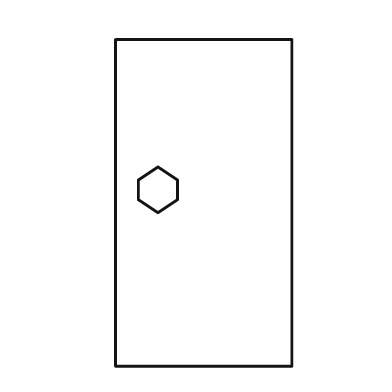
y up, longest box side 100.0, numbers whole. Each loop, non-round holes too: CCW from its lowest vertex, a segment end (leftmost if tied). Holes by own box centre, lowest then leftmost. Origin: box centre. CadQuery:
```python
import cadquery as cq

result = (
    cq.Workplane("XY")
    .moveTo(-27.0, -50.0)
    .lineTo(27.0, -50.0)
    .lineTo(27.0, 50.0)
    .lineTo(-27.0, 50.0)
    .close()
    .moveTo(-14.0, -3.0)
    .lineTo(-8.0, 1.0)
    .lineTo(-8.0, 7.0)
    .lineTo(-14.0, 11.0)
    .lineTo(-20.0, 7.0)
    .lineTo(-20.0, 1.0)
    .close()
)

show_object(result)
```